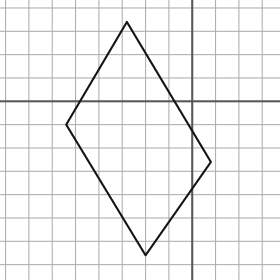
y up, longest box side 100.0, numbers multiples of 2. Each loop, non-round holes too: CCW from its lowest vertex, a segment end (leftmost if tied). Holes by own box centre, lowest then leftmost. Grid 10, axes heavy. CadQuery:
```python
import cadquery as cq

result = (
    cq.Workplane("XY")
    .moveTo(-20.0, -66.0)
    .lineTo(8.0, -26.0)
    .lineTo(-28.0, 34.0)
    .lineTo(-54.0, -10.0)
    .close()
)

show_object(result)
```